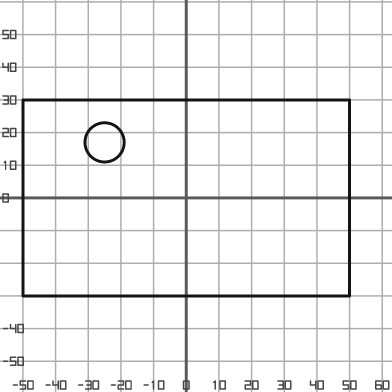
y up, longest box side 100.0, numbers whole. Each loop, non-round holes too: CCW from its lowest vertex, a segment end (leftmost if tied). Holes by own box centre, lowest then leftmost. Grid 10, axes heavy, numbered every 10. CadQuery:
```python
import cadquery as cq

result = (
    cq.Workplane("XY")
    .moveTo(-50.0, -30.0)
    .lineTo(50.0, -30.0)
    .lineTo(50.0, 30.0)
    .lineTo(-50.0, 30.0)
    .close()
    .moveTo(-25.0, 17.0)
    .circle(6.0)
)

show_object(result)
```